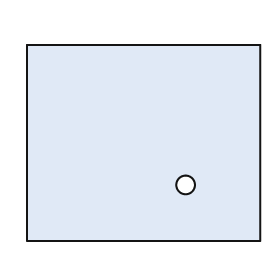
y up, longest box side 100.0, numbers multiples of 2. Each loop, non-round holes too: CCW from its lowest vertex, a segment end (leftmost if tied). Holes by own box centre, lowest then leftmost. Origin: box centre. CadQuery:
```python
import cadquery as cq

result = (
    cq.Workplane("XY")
    .moveTo(-50.0, -42.0)
    .lineTo(50.0, -42.0)
    .lineTo(50.0, 42.0)
    .lineTo(-50.0, 42.0)
    .close()
    .moveTo(18.0, -18.0)
    .circle(4.0)
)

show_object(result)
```